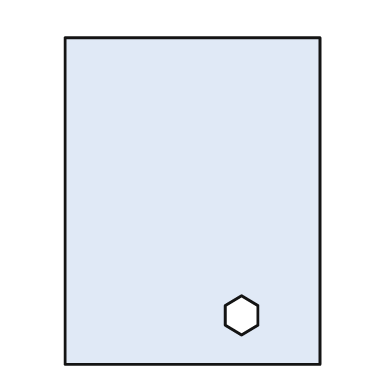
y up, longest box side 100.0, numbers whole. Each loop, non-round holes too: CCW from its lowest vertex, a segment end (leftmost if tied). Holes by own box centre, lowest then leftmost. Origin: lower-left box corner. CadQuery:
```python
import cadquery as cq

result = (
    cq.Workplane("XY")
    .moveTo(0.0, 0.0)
    .lineTo(78.0, 0.0)
    .lineTo(78.0, 100.0)
    .lineTo(0.0, 100.0)
    .close()
    .moveTo(54.0, 9.0)
    .lineTo(59.0, 12.0)
    .lineTo(59.0, 18.0)
    .lineTo(54.0, 21.0)
    .lineTo(49.0, 18.0)
    .lineTo(49.0, 12.0)
    .close()
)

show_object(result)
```